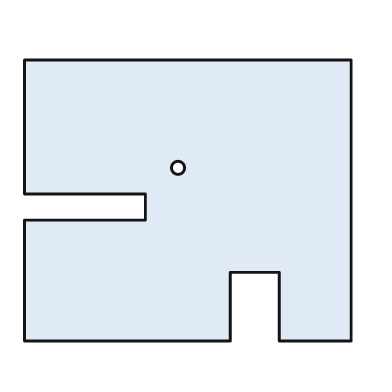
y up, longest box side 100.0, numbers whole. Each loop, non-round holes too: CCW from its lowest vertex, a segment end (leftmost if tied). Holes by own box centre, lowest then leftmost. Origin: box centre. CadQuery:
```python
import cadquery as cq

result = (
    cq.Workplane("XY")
    .moveTo(-50.0, -43.0)
    .lineTo(13.0, -43.0)
    .lineTo(13.0, -22.0)
    .lineTo(28.0, -22.0)
    .lineTo(28.0, -43.0)
    .lineTo(50.0, -43.0)
    .lineTo(50.0, 43.0)
    .lineTo(-50.0, 43.0)
    .lineTo(-50.0, 2.0)
    .lineTo(-13.0, 2.0)
    .lineTo(-13.0, -6.0)
    .lineTo(-50.0, -6.0)
    .close()
    .moveTo(-3.0, 10.0)
    .circle(2.0)
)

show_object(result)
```